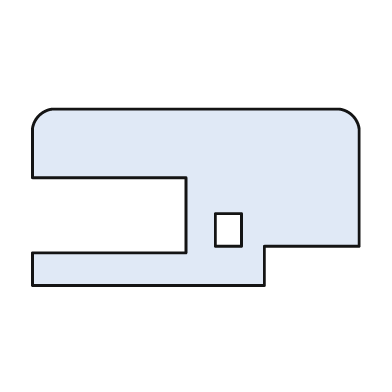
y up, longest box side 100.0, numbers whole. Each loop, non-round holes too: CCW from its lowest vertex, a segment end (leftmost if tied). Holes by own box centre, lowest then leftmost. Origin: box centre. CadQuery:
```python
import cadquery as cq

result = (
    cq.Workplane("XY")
    .moveTo(-50.0, -27.0)
    .lineTo(21.0, -27.0)
    .lineTo(21.0, -15.0)
    .lineTo(50.0, -15.0)
    .lineTo(50.0, 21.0)
    .threePointArc((48.0, 25.0), (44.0, 27.0))
    .lineTo(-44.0, 27.0)
    .threePointArc((-48.0, 25.0), (-50.0, 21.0))
    .lineTo(-50.0, 6.0)
    .lineTo(-3.0, 6.0)
    .lineTo(-3.0, -17.0)
    .lineTo(-50.0, -17.0)
    .close()
    .moveTo(6.0, -15.0)
    .lineTo(14.0, -15.0)
    .lineTo(14.0, -5.0)
    .lineTo(6.0, -5.0)
    .close()
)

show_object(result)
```